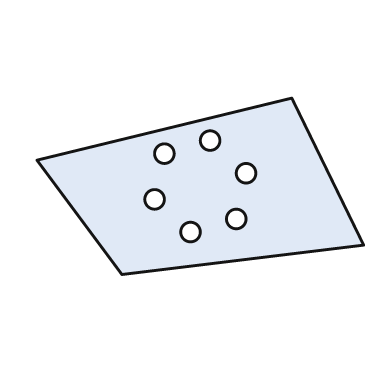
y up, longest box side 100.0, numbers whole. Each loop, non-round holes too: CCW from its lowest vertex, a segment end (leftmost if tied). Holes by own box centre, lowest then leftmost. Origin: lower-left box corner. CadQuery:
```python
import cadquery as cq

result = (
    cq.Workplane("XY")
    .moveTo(26.0, 0.0)
    .lineTo(100.0, 9.0)
    .lineTo(78.0, 54.0)
    .lineTo(0.0, 35.0)
    .close()
    .moveTo(47.0, 13.0)
    .circle(3.0)
    .moveTo(61.0, 17.0)
    .circle(3.0)
    .moveTo(36.0, 23.0)
    .circle(3.0)
    .moveTo(64.0, 31.0)
    .circle(3.0)
    .moveTo(39.0, 37.0)
    .circle(3.0)
    .moveTo(53.0, 41.0)
    .circle(3.0)
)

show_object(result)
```